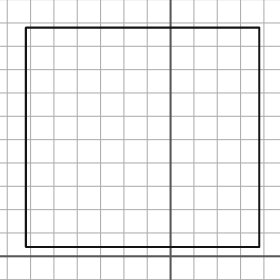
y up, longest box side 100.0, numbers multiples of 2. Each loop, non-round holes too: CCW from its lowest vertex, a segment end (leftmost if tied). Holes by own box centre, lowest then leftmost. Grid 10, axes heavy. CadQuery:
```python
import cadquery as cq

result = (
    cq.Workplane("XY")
    .moveTo(-62.0, 4.0)
    .lineTo(38.0, 4.0)
    .lineTo(38.0, 98.0)
    .lineTo(-62.0, 98.0)
    .close()
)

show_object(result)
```